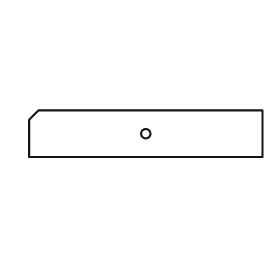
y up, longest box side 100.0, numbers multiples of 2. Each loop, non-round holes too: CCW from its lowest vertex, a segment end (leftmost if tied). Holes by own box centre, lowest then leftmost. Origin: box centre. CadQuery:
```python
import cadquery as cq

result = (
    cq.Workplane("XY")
    .moveTo(-50.0, -10.0)
    .lineTo(50.0, -10.0)
    .lineTo(50.0, 10.0)
    .lineTo(-46.0, 10.0)
    .lineTo(-50.0, 6.0)
    .close()
    .moveTo(0.0, 0.0)
    .circle(2.0)
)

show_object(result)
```